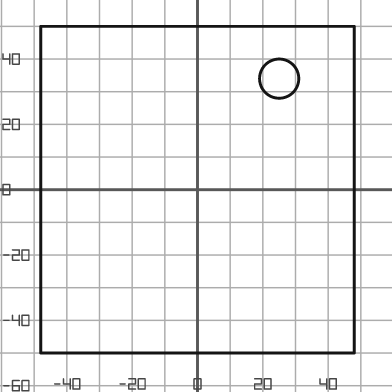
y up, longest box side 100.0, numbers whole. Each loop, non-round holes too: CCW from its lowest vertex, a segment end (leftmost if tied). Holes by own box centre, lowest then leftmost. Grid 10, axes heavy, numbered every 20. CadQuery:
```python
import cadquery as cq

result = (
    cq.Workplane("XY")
    .moveTo(-48.0, -50.0)
    .lineTo(48.0, -50.0)
    .lineTo(48.0, 50.0)
    .lineTo(-48.0, 50.0)
    .close()
    .moveTo(25.0, 34.0)
    .circle(6.0)
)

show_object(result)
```